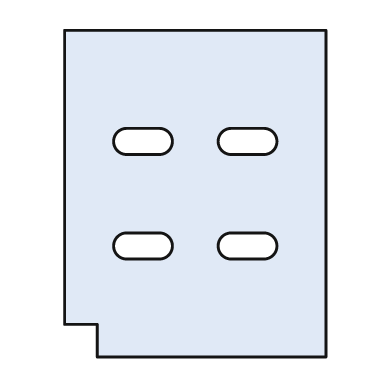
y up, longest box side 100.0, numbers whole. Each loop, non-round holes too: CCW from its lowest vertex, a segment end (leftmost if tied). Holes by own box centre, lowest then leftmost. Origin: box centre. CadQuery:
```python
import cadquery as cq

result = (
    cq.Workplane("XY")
    .moveTo(-30.0, -50.0)
    .lineTo(40.0, -50.0)
    .lineTo(40.0, 50.0)
    .lineTo(-40.0, 50.0)
    .lineTo(-40.0, -40.0)
    .lineTo(-30.0, -40.0)
    .close()
    .moveTo(-21.0, -20.0)
    .lineTo(-11.0, -20.0)
    .threePointArc((-7.0, -16.0), (-11.0, -12.0))
    .lineTo(-21.0, -12.0)
    .threePointArc((-25.0, -16.0), (-21.0, -20.0))
    .close()
    .moveTo(11.0, -20.0)
    .lineTo(21.0, -20.0)
    .threePointArc((25.0, -16.0), (21.0, -12.0))
    .lineTo(11.0, -12.0)
    .threePointArc((7.0, -16.0), (11.0, -20.0))
    .close()
    .moveTo(-21.0, 12.0)
    .lineTo(-11.0, 12.0)
    .threePointArc((-7.0, 16.0), (-11.0, 20.0))
    .lineTo(-21.0, 20.0)
    .threePointArc((-25.0, 16.0), (-21.0, 12.0))
    .close()
    .moveTo(11.0, 12.0)
    .lineTo(21.0, 12.0)
    .threePointArc((25.0, 16.0), (21.0, 20.0))
    .lineTo(11.0, 20.0)
    .threePointArc((7.0, 16.0), (11.0, 12.0))
    .close()
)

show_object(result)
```